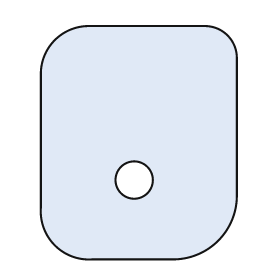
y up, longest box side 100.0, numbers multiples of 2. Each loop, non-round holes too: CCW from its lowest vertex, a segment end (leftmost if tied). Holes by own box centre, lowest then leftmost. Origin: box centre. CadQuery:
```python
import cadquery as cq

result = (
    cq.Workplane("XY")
    .moveTo(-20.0, -50.0)
    .lineTo(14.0, -50.0)
    .threePointArc((34.0, -42.0), (42.0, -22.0))
    .lineTo(42.0, 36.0)
    .threePointArc((38.0, 46.0), (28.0, 50.0))
    .lineTo(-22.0, 50.0)
    .threePointArc((-36.0, 44.0), (-42.0, 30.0))
    .lineTo(-42.0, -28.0)
    .threePointArc((-36.0, -44.0), (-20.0, -50.0))
    .close()
    .moveTo(-2.0, -16.0)
    .circle(8.0)
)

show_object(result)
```